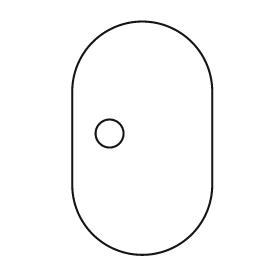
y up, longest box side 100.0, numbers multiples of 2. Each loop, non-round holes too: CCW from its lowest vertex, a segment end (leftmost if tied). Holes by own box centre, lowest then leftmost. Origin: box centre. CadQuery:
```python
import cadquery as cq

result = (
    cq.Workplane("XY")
    .moveTo(-30.0, -20.0)
    .threePointArc((0.0, -50.0), (30.0, -20.0))
    .lineTo(30.0, 20.0)
    .threePointArc((0.0, 50.0), (-30.0, 20.0))
    .close()
    .moveTo(-14.0, 2.0)
    .circle(6.0)
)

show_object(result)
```